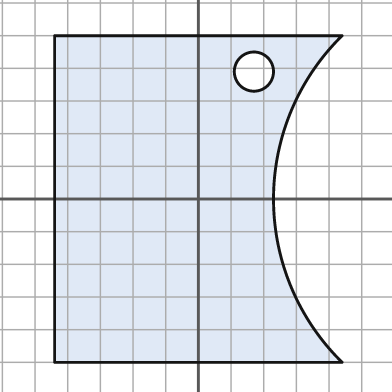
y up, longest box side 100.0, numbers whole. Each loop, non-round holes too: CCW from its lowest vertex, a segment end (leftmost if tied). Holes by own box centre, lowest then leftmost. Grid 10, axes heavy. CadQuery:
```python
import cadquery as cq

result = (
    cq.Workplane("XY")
    .moveTo(-44.0, -50.0)
    .lineTo(44.0, -50.0)
    .threePointArc((23.0, 0.0), (44.0, 50.0))
    .lineTo(-44.0, 50.0)
    .close()
    .moveTo(17.0, 39.0)
    .circle(6.0)
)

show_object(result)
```